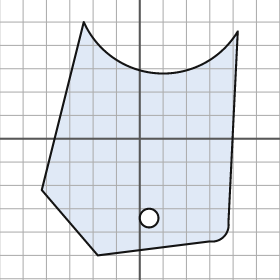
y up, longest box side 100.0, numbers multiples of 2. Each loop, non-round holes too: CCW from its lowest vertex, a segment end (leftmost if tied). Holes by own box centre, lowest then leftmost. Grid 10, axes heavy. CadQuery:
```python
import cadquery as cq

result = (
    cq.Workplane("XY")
    .moveTo(-18.0, -50.0)
    .lineTo(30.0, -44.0)
    .threePointArc((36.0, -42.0), (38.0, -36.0))
    .lineTo(42.0, 46.0)
    .threePointArc((8.0, 28.0), (-24.0, 50.0))
    .lineTo(-42.0, -22.0)
    .close()
    .moveTo(4.0, -34.0)
    .circle(4.0)
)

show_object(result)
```